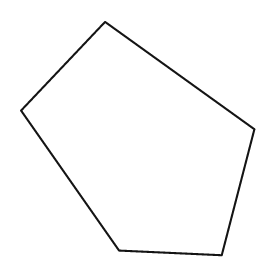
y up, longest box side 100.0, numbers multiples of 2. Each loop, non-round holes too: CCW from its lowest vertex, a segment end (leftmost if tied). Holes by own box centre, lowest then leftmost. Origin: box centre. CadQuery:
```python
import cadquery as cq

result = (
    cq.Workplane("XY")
    .moveTo(36.0, -50.0)
    .lineTo(50.0, 4.0)
    .lineTo(-14.0, 50.0)
    .lineTo(-50.0, 12.0)
    .lineTo(-8.0, -48.0)
    .close()
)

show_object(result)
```